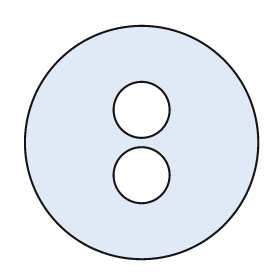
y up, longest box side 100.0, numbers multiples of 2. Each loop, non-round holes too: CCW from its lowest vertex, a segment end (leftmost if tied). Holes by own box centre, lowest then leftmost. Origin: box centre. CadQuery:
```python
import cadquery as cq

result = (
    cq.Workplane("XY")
    .moveTo(0.0, 0.0)
    .circle(50.0)
    .moveTo(0.0, -14.0)
    .circle(12.0)
    .moveTo(0.0, 14.0)
    .circle(12.0)
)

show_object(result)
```